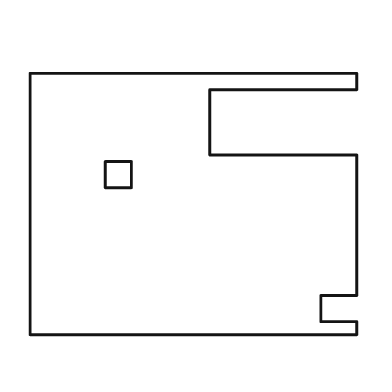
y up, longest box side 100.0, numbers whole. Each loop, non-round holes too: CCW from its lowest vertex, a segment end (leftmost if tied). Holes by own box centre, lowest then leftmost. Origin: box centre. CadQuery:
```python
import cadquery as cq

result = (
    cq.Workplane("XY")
    .moveTo(-50.0, -40.0)
    .lineTo(50.0, -40.0)
    .lineTo(50.0, -36.0)
    .lineTo(39.0, -36.0)
    .lineTo(39.0, -28.0)
    .lineTo(50.0, -28.0)
    .lineTo(50.0, 15.0)
    .lineTo(5.0, 15.0)
    .lineTo(5.0, 35.0)
    .lineTo(50.0, 35.0)
    .lineTo(50.0, 40.0)
    .lineTo(-50.0, 40.0)
    .close()
    .moveTo(-27.0, 5.0)
    .lineTo(-19.0, 5.0)
    .lineTo(-19.0, 13.0)
    .lineTo(-27.0, 13.0)
    .close()
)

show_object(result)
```